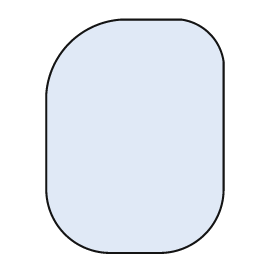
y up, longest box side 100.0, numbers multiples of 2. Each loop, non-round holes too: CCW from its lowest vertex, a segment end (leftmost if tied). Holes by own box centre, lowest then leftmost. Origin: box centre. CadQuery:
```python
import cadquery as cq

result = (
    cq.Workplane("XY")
    .moveTo(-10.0, -50.0)
    .lineTo(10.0, -50.0)
    .threePointArc((30.0, -42.0), (38.0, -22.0))
    .lineTo(38.0, 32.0)
    .threePointArc((32.0, 44.0), (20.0, 50.0))
    .lineTo(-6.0, 50.0)
    .threePointArc((-28.0, 40.0), (-38.0, 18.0))
    .lineTo(-38.0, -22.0)
    .threePointArc((-30.0, -42.0), (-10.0, -50.0))
    .close()
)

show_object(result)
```